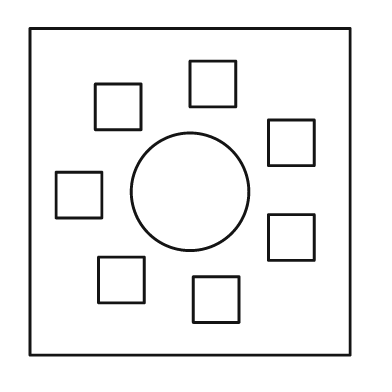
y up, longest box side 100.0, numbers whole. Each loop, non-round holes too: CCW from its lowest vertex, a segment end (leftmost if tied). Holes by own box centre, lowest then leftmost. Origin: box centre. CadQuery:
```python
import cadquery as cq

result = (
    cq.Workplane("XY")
    .moveTo(-49.0, -50.0)
    .lineTo(49.0, -50.0)
    .lineTo(49.0, 50.0)
    .lineTo(-49.0, 50.0)
    .close()
    .moveTo(1.0, -40.0)
    .lineTo(15.0, -40.0)
    .lineTo(15.0, -26.0)
    .lineTo(1.0, -26.0)
    .close()
    .moveTo(-28.0, -34.0)
    .lineTo(-14.0, -34.0)
    .lineTo(-14.0, -20.0)
    .lineTo(-28.0, -20.0)
    .close()
    .moveTo(24.0, -21.0)
    .lineTo(38.0, -21.0)
    .lineTo(38.0, -7.0)
    .lineTo(24.0, -7.0)
    .close()
    .moveTo(-41.0, -8.0)
    .lineTo(-27.0, -8.0)
    .lineTo(-27.0, 6.0)
    .lineTo(-41.0, 6.0)
    .close()
    .moveTo(0.0, 0.0)
    .circle(18.0)
    .moveTo(24.0, 8.0)
    .lineTo(38.0, 8.0)
    .lineTo(38.0, 22.0)
    .lineTo(24.0, 22.0)
    .close()
    .moveTo(-29.0, 19.0)
    .lineTo(-15.0, 19.0)
    .lineTo(-15.0, 33.0)
    .lineTo(-29.0, 33.0)
    .close()
    .moveTo(0.0, 26.0)
    .lineTo(14.0, 26.0)
    .lineTo(14.0, 40.0)
    .lineTo(0.0, 40.0)
    .close()
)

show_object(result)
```